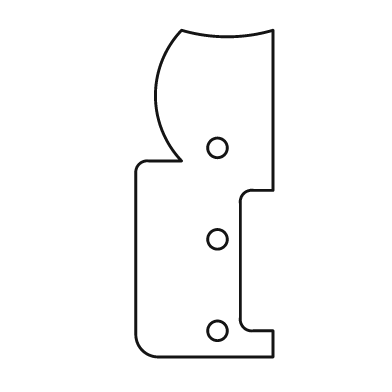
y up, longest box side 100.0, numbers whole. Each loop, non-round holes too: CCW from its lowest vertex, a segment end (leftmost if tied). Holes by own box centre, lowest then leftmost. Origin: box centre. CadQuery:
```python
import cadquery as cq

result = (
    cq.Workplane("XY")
    .moveTo(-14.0, -50.0)
    .lineTo(21.0, -50.0)
    .lineTo(21.0, -42.0)
    .lineTo(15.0, -42.0)
    .threePointArc((12.0, -41.0), (11.0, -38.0))
    .lineTo(11.0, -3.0)
    .threePointArc((12.0, 0.0), (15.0, 1.0))
    .lineTo(21.0, 1.0)
    .lineTo(21.0, 50.0)
    .threePointArc((7.0, 48.0), (-7.0, 50.0))
    .threePointArc((-15.0, 30.0), (-7.0, 10.0))
    .lineTo(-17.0, 10.0)
    .threePointArc((-20.0, 9.0), (-21.0, 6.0))
    .lineTo(-21.0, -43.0)
    .threePointArc((-19.0, -48.0), (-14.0, -50.0))
    .close()
    .moveTo(4.0, -42.0)
    .circle(3.0)
    .moveTo(4.0, -14.0)
    .circle(3.0)
    .moveTo(4.0, 14.0)
    .circle(3.0)
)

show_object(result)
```